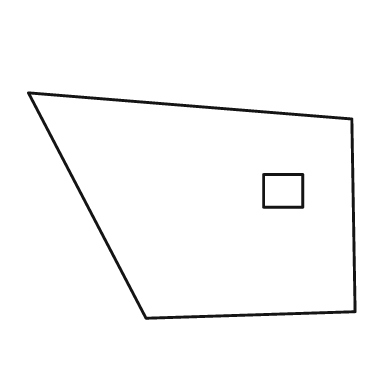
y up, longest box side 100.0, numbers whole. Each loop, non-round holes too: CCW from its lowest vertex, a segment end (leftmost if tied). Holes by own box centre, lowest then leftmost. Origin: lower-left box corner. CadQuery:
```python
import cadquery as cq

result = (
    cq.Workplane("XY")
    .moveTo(36.0, 0.0)
    .lineTo(100.0, 2.0)
    .lineTo(99.0, 61.0)
    .lineTo(0.0, 69.0)
    .close()
    .moveTo(72.0, 34.0)
    .lineTo(84.0, 34.0)
    .lineTo(84.0, 44.0)
    .lineTo(72.0, 44.0)
    .close()
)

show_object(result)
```